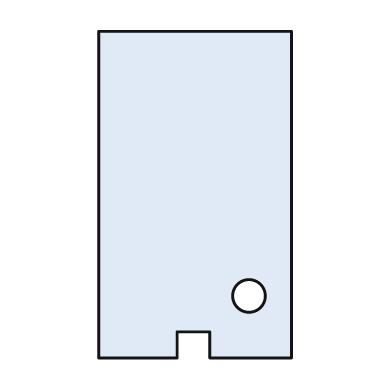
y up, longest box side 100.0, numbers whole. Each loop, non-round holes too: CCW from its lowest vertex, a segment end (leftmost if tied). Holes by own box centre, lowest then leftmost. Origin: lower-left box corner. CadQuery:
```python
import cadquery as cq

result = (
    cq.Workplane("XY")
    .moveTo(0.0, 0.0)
    .lineTo(24.0, 0.0)
    .lineTo(24.0, 8.0)
    .lineTo(34.0, 8.0)
    .lineTo(34.0, 0.0)
    .lineTo(59.0, 0.0)
    .lineTo(59.0, 100.0)
    .lineTo(0.0, 100.0)
    .close()
    .moveTo(46.0, 19.0)
    .circle(5.0)
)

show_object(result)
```